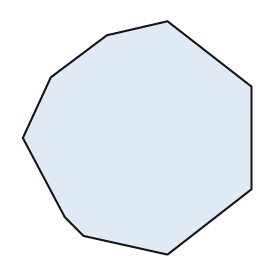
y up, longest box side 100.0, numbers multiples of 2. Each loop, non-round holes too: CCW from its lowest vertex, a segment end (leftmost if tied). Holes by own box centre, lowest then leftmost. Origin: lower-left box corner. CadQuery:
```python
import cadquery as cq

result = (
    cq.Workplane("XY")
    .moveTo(62.0, 0.0)
    .lineTo(98.0, 28.0)
    .lineTo(98.0, 72.0)
    .lineTo(62.0, 100.0)
    .lineTo(36.0, 94.0)
    .lineTo(12.0, 76.0)
    .lineTo(0.0, 50.0)
    .lineTo(18.0, 16.0)
    .lineTo(26.0, 8.0)
    .close()
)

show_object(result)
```